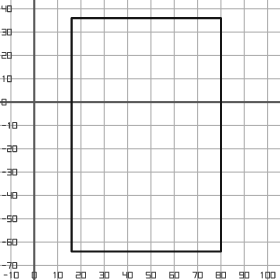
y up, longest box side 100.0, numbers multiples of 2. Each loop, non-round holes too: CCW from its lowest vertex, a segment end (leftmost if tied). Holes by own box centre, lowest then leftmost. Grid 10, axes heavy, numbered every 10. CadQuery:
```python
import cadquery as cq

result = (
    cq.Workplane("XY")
    .moveTo(16.0, -64.0)
    .lineTo(80.0, -64.0)
    .lineTo(80.0, 36.0)
    .lineTo(16.0, 36.0)
    .close()
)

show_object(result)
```